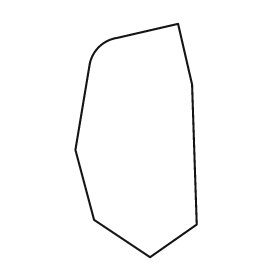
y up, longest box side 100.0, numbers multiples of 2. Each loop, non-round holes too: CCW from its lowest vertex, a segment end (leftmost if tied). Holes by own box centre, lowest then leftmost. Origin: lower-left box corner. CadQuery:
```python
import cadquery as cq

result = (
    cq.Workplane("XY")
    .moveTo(32.0, 0.0)
    .lineTo(52.0, 14.0)
    .lineTo(50.0, 74.0)
    .lineTo(44.0, 100.0)
    .lineTo(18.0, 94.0)
    .threePointArc((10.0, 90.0), (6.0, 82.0))
    .lineTo(0.0, 46.0)
    .lineTo(8.0, 16.0)
    .close()
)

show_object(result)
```